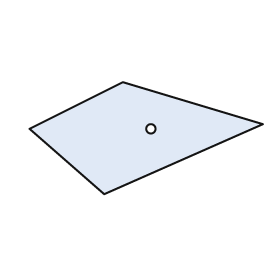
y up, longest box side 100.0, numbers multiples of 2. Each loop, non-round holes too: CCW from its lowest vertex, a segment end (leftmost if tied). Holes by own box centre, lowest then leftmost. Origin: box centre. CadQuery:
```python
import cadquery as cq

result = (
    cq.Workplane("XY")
    .moveTo(-18.0, -24.0)
    .lineTo(50.0, 6.0)
    .lineTo(-10.0, 24.0)
    .lineTo(-50.0, 4.0)
    .close()
    .moveTo(2.0, 4.0)
    .circle(2.0)
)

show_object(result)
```